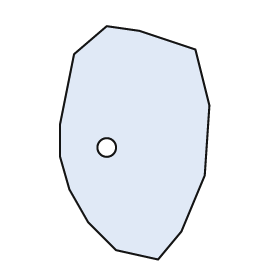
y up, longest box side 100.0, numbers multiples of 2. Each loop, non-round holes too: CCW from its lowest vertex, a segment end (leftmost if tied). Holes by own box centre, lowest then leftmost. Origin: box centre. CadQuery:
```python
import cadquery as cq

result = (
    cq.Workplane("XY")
    .moveTo(10.0, -50.0)
    .lineTo(20.0, -38.0)
    .lineTo(30.0, -14.0)
    .lineTo(32.0, 16.0)
    .lineTo(26.0, 40.0)
    .lineTo(2.0, 48.0)
    .lineTo(-12.0, 50.0)
    .lineTo(-26.0, 38.0)
    .lineTo(-32.0, 8.0)
    .lineTo(-32.0, -6.0)
    .lineTo(-28.0, -20.0)
    .lineTo(-20.0, -34.0)
    .lineTo(-8.0, -46.0)
    .close()
    .moveTo(-12.0, -2.0)
    .circle(4.0)
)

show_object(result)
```